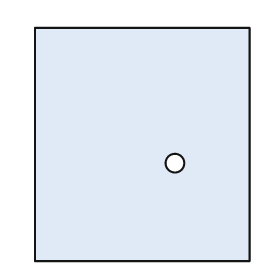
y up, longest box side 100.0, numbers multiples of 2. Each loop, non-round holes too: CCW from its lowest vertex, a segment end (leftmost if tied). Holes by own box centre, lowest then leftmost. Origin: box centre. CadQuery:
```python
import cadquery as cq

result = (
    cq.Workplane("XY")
    .moveTo(-46.0, -50.0)
    .lineTo(46.0, -50.0)
    .lineTo(46.0, 50.0)
    .lineTo(-46.0, 50.0)
    .close()
    .moveTo(14.0, -8.0)
    .circle(4.0)
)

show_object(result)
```